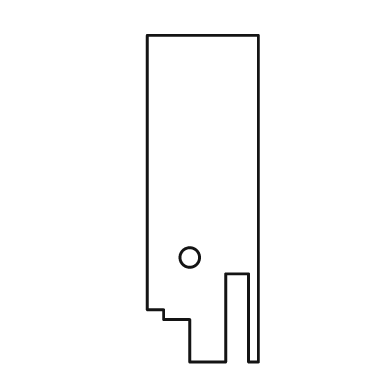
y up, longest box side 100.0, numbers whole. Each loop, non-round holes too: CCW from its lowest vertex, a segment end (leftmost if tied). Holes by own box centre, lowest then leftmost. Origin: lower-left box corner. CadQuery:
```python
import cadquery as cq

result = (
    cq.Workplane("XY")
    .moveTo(13.0, 0.0)
    .lineTo(24.0, 0.0)
    .lineTo(24.0, 27.0)
    .lineTo(31.0, 27.0)
    .lineTo(31.0, 0.0)
    .lineTo(34.0, 0.0)
    .lineTo(34.0, 100.0)
    .lineTo(0.0, 100.0)
    .lineTo(0.0, 16.0)
    .lineTo(5.0, 16.0)
    .lineTo(5.0, 13.0)
    .lineTo(13.0, 13.0)
    .close()
    .moveTo(13.0, 32.0)
    .circle(3.0)
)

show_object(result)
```